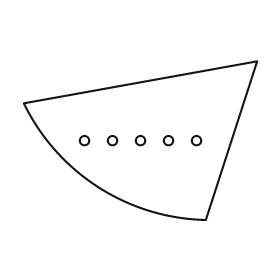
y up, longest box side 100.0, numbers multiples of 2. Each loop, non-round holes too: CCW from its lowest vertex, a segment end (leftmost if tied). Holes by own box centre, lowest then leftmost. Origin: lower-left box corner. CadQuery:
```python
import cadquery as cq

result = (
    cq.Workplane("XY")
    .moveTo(78.0, 0.0)
    .lineTo(100.0, 68.0)
    .lineTo(0.0, 50.0)
    .threePointArc((32.0, 14.0), (78.0, 0.0))
    .close()
    .moveTo(26.0, 34.0)
    .circle(2.0)
    .moveTo(38.0, 34.0)
    .circle(2.0)
    .moveTo(50.0, 34.0)
    .circle(2.0)
    .moveTo(62.0, 34.0)
    .circle(2.0)
    .moveTo(74.0, 34.0)
    .circle(2.0)
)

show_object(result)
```